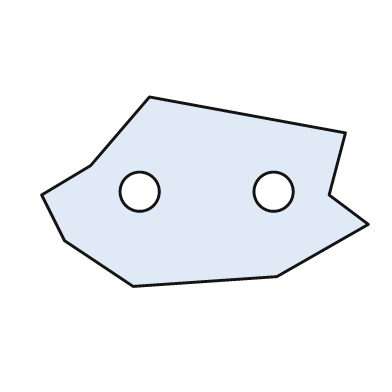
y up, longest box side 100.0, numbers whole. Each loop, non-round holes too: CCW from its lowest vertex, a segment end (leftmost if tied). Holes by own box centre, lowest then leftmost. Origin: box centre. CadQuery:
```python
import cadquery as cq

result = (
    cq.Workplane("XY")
    .moveTo(-22.0, -29.0)
    .lineTo(22.0, -26.0)
    .lineTo(50.0, -10.0)
    .lineTo(38.0, -1.0)
    .lineTo(43.0, 18.0)
    .lineTo(-17.0, 29.0)
    .lineTo(-35.0, 8.0)
    .lineTo(-50.0, -1.0)
    .lineTo(-43.0, -15.0)
    .close()
    .moveTo(-20.0, 0.0)
    .circle(6.0)
    .moveTo(21.0, 0.0)
    .circle(6.0)
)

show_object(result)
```